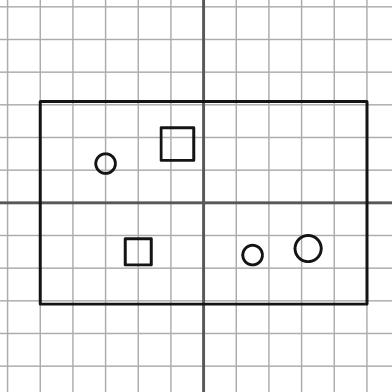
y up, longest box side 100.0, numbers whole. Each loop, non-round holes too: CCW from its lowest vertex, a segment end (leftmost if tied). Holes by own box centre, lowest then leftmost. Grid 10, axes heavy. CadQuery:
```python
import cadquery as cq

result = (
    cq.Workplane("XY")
    .moveTo(-50.0, -31.0)
    .lineTo(50.0, -31.0)
    .lineTo(50.0, 31.0)
    .lineTo(-50.0, 31.0)
    .close()
    .moveTo(15.0, -16.0)
    .circle(3.0)
    .moveTo(-24.0, -19.0)
    .lineTo(-16.0, -19.0)
    .lineTo(-16.0, -11.0)
    .lineTo(-24.0, -11.0)
    .close()
    .moveTo(32.0, -14.0)
    .circle(4.0)
    .moveTo(-30.0, 12.0)
    .circle(3.0)
    .moveTo(-13.0, 13.0)
    .lineTo(-3.0, 13.0)
    .lineTo(-3.0, 23.0)
    .lineTo(-13.0, 23.0)
    .close()
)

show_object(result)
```